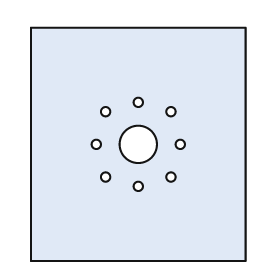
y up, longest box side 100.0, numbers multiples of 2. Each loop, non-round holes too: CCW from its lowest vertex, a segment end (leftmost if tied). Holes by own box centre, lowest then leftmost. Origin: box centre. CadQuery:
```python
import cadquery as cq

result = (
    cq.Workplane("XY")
    .moveTo(-46.0, -50.0)
    .lineTo(46.0, -50.0)
    .lineTo(46.0, 50.0)
    .lineTo(-46.0, 50.0)
    .close()
    .moveTo(0.0, -18.0)
    .circle(2.0)
    .moveTo(-14.0, -14.0)
    .circle(2.0)
    .moveTo(14.0, -14.0)
    .circle(2.0)
    .moveTo(-18.0, 0.0)
    .circle(2.0)
    .moveTo(0.0, 0.0)
    .circle(8.0)
    .moveTo(18.0, 0.0)
    .circle(2.0)
    .moveTo(-14.0, 14.0)
    .circle(2.0)
    .moveTo(14.0, 14.0)
    .circle(2.0)
    .moveTo(0.0, 18.0)
    .circle(2.0)
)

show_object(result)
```